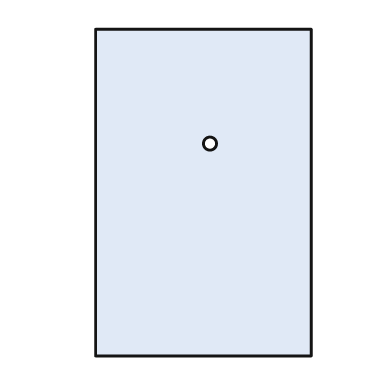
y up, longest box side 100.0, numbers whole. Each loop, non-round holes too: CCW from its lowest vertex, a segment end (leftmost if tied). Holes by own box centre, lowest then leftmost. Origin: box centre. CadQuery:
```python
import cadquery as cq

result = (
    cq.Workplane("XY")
    .moveTo(-33.0, -50.0)
    .lineTo(33.0, -50.0)
    .lineTo(33.0, 50.0)
    .lineTo(-33.0, 50.0)
    .close()
    .moveTo(2.0, 15.0)
    .circle(2.0)
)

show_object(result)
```